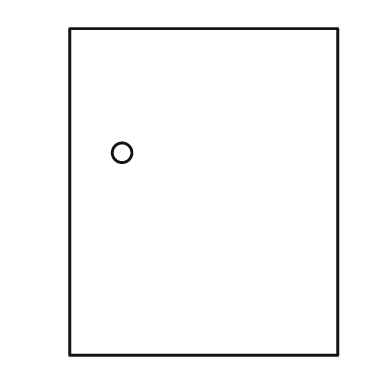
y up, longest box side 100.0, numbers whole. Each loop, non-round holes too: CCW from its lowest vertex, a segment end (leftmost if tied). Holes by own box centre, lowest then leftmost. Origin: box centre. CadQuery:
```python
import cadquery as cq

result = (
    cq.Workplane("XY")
    .moveTo(-41.0, -50.0)
    .lineTo(41.0, -50.0)
    .lineTo(41.0, 50.0)
    .lineTo(-41.0, 50.0)
    .close()
    .moveTo(-25.0, 12.0)
    .circle(3.0)
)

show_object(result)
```